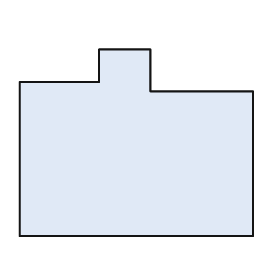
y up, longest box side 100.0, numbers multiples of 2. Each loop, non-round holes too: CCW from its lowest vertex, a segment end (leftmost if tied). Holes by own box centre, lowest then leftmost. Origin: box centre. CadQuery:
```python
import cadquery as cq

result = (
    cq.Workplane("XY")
    .moveTo(-50.0, -40.0)
    .lineTo(50.0, -40.0)
    .lineTo(50.0, 22.0)
    .lineTo(6.0, 22.0)
    .lineTo(6.0, 40.0)
    .lineTo(-16.0, 40.0)
    .lineTo(-16.0, 26.0)
    .lineTo(-50.0, 26.0)
    .close()
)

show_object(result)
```